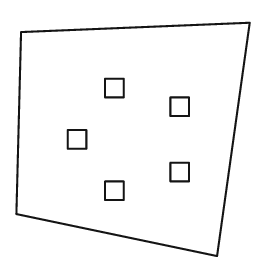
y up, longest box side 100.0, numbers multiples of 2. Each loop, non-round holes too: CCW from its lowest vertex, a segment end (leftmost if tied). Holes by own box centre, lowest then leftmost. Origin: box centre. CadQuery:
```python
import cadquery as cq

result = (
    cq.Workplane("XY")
    .moveTo(36.0, -50.0)
    .lineTo(50.0, 50.0)
    .lineTo(-48.0, 46.0)
    .lineTo(-50.0, -32.0)
    .close()
    .moveTo(-12.0, -26.0)
    .lineTo(-4.0, -26.0)
    .lineTo(-4.0, -18.0)
    .lineTo(-12.0, -18.0)
    .close()
    .moveTo(16.0, -18.0)
    .lineTo(24.0, -18.0)
    .lineTo(24.0, -10.0)
    .lineTo(16.0, -10.0)
    .close()
    .moveTo(-28.0, -4.0)
    .lineTo(-20.0, -4.0)
    .lineTo(-20.0, 4.0)
    .lineTo(-28.0, 4.0)
    .close()
    .moveTo(16.0, 10.0)
    .lineTo(24.0, 10.0)
    .lineTo(24.0, 18.0)
    .lineTo(16.0, 18.0)
    .close()
    .moveTo(-12.0, 18.0)
    .lineTo(-4.0, 18.0)
    .lineTo(-4.0, 26.0)
    .lineTo(-12.0, 26.0)
    .close()
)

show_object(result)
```